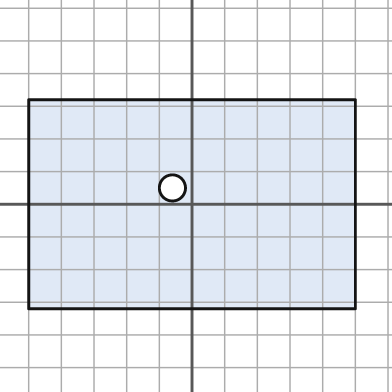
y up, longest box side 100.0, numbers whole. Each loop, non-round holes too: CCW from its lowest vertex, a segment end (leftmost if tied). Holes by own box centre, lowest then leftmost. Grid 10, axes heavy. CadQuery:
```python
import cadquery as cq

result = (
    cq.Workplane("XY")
    .moveTo(-50.0, -32.0)
    .lineTo(50.0, -32.0)
    .lineTo(50.0, 32.0)
    .lineTo(-50.0, 32.0)
    .close()
    .moveTo(-6.0, 5.0)
    .circle(4.0)
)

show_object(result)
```